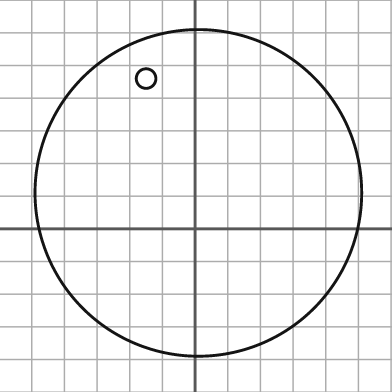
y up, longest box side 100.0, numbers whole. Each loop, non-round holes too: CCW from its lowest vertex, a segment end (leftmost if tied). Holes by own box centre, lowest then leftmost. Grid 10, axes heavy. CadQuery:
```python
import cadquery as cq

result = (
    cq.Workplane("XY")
    .moveTo(1.0, 11.0)
    .circle(50.0)
    .moveTo(-15.0, 46.0)
    .circle(3.0)
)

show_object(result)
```